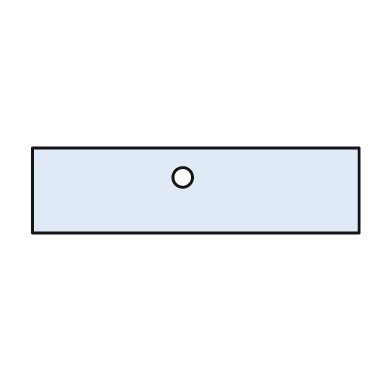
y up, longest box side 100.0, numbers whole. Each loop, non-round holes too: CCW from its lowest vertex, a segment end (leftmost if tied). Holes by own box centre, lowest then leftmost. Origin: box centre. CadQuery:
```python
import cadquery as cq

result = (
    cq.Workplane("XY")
    .moveTo(-50.0, -13.0)
    .lineTo(50.0, -13.0)
    .lineTo(50.0, 13.0)
    .lineTo(-50.0, 13.0)
    .close()
    .moveTo(-4.0, 4.0)
    .circle(3.0)
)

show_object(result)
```